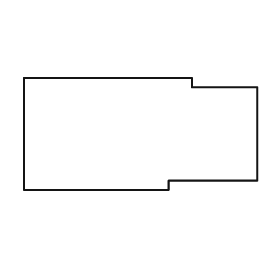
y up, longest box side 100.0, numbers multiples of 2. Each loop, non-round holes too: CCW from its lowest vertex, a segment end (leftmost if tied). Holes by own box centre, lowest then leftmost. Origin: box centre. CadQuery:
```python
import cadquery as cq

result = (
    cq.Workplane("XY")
    .moveTo(-50.0, -24.0)
    .lineTo(12.0, -24.0)
    .lineTo(12.0, -20.0)
    .lineTo(50.0, -20.0)
    .lineTo(50.0, 20.0)
    .lineTo(22.0, 20.0)
    .lineTo(22.0, 24.0)
    .lineTo(-50.0, 24.0)
    .close()
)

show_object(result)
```